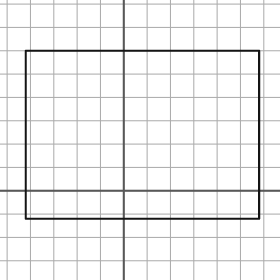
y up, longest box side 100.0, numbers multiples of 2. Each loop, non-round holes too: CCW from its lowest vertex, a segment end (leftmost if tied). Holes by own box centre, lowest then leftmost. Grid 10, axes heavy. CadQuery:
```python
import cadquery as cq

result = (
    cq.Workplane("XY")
    .moveTo(-42.0, -12.0)
    .lineTo(58.0, -12.0)
    .lineTo(58.0, 60.0)
    .lineTo(-42.0, 60.0)
    .close()
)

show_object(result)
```